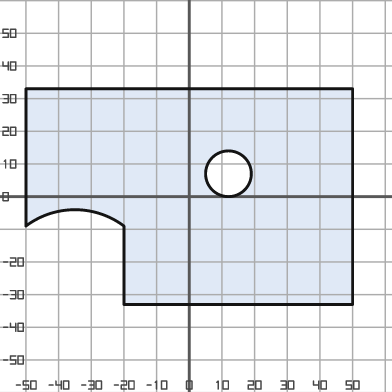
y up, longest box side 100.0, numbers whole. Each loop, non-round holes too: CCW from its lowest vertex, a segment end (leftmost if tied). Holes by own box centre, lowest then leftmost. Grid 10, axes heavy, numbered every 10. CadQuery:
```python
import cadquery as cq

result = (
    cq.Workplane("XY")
    .moveTo(-20.0, -33.0)
    .lineTo(50.0, -33.0)
    .lineTo(50.0, 33.0)
    .lineTo(-50.0, 33.0)
    .lineTo(-50.0, -9.0)
    .threePointArc((-35.0, -4.0), (-20.0, -9.0))
    .close()
    .moveTo(12.0, 7.0)
    .circle(7.0)
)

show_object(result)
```